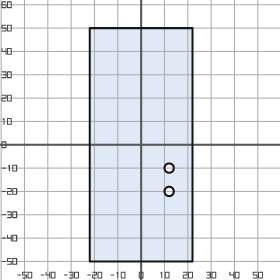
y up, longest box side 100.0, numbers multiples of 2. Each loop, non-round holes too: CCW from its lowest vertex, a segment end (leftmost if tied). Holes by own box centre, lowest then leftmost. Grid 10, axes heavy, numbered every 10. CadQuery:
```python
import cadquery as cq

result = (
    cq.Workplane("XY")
    .moveTo(-22.0, -50.0)
    .lineTo(22.0, -50.0)
    .lineTo(22.0, 50.0)
    .lineTo(-22.0, 50.0)
    .close()
    .moveTo(12.0, -20.0)
    .circle(2.0)
    .moveTo(12.0, -10.0)
    .circle(2.0)
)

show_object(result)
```